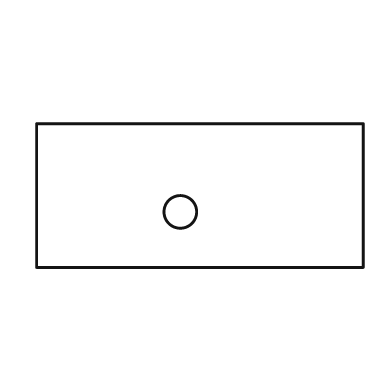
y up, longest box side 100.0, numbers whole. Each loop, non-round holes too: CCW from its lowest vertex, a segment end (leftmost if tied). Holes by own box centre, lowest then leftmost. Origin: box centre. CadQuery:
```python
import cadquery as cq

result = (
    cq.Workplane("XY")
    .moveTo(-50.0, -22.0)
    .lineTo(50.0, -22.0)
    .lineTo(50.0, 22.0)
    .lineTo(-50.0, 22.0)
    .close()
    .moveTo(-6.0, -5.0)
    .circle(5.0)
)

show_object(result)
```